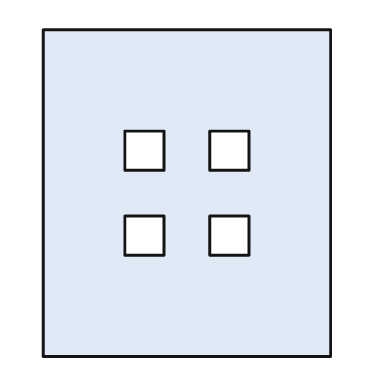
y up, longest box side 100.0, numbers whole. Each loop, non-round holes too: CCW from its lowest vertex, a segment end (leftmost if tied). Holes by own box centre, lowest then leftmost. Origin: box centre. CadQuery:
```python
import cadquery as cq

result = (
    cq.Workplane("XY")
    .moveTo(-44.0, -50.0)
    .lineTo(44.0, -50.0)
    .lineTo(44.0, 50.0)
    .lineTo(-44.0, 50.0)
    .close()
    .moveTo(-19.0, -19.0)
    .lineTo(-7.0, -19.0)
    .lineTo(-7.0, -7.0)
    .lineTo(-19.0, -7.0)
    .close()
    .moveTo(7.0, -19.0)
    .lineTo(19.0, -19.0)
    .lineTo(19.0, -7.0)
    .lineTo(7.0, -7.0)
    .close()
    .moveTo(-19.0, 7.0)
    .lineTo(-7.0, 7.0)
    .lineTo(-7.0, 19.0)
    .lineTo(-19.0, 19.0)
    .close()
    .moveTo(7.0, 7.0)
    .lineTo(19.0, 7.0)
    .lineTo(19.0, 19.0)
    .lineTo(7.0, 19.0)
    .close()
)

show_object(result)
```